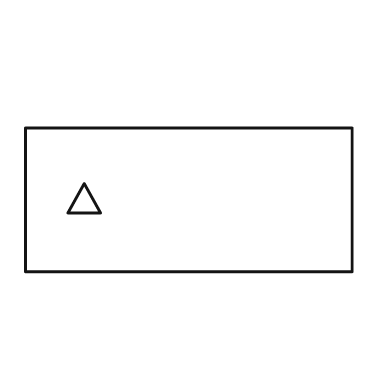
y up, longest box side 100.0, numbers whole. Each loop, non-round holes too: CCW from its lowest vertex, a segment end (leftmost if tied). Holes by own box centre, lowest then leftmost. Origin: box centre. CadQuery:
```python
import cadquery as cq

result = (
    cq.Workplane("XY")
    .moveTo(-50.0, -22.0)
    .lineTo(50.0, -22.0)
    .lineTo(50.0, 22.0)
    .lineTo(-50.0, 22.0)
    .close()
    .moveTo(-37.0, -4.0)
    .lineTo(-27.0, -4.0)
    .lineTo(-32.0, 5.0)
    .close()
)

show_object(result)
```